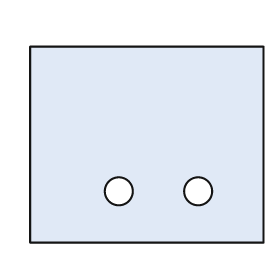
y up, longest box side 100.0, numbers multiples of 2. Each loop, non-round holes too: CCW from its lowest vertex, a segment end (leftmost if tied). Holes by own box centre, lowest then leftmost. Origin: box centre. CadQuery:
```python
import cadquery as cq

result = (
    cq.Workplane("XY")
    .moveTo(-50.0, -42.0)
    .lineTo(50.0, -42.0)
    .lineTo(50.0, 42.0)
    .lineTo(-50.0, 42.0)
    .close()
    .moveTo(-12.0, -20.0)
    .circle(6.0)
    .moveTo(22.0, -20.0)
    .circle(6.0)
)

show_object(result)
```